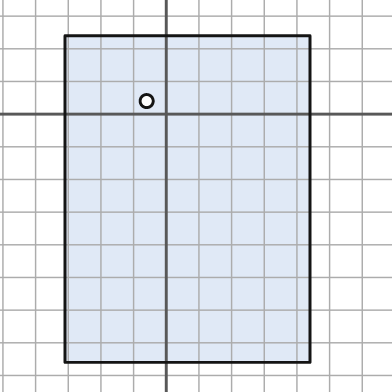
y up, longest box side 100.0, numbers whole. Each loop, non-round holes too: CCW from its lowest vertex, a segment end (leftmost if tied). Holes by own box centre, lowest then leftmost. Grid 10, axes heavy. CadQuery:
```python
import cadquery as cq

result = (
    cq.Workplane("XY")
    .moveTo(-31.0, -76.0)
    .lineTo(44.0, -76.0)
    .lineTo(44.0, 24.0)
    .lineTo(-31.0, 24.0)
    .close()
    .moveTo(-6.0, 4.0)
    .circle(2.0)
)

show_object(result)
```